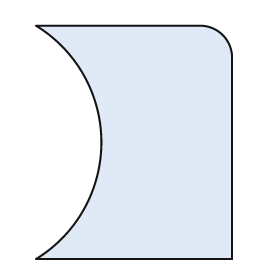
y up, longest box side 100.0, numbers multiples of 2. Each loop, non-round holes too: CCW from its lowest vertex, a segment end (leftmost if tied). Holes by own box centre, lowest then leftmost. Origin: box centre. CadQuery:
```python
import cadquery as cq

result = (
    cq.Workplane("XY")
    .moveTo(-42.0, -50.0)
    .lineTo(42.0, -50.0)
    .lineTo(42.0, 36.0)
    .threePointArc((38.0, 46.0), (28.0, 50.0))
    .lineTo(-42.0, 50.0)
    .threePointArc((-14.0, 0.0), (-42.0, -50.0))
    .close()
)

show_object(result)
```